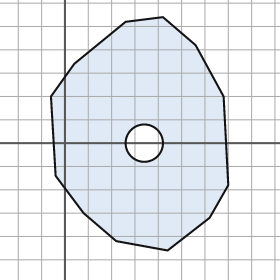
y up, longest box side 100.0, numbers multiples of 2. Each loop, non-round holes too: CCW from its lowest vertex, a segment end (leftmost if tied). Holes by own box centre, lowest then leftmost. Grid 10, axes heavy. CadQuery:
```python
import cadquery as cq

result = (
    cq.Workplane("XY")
    .moveTo(44.0, -46.0)
    .lineTo(62.0, -32.0)
    .lineTo(70.0, -18.0)
    .lineTo(68.0, 20.0)
    .lineTo(56.0, 42.0)
    .lineTo(42.0, 54.0)
    .lineTo(26.0, 52.0)
    .lineTo(4.0, 34.0)
    .lineTo(-6.0, 20.0)
    .lineTo(-4.0, -14.0)
    .lineTo(8.0, -30.0)
    .lineTo(22.0, -42.0)
    .close()
    .moveTo(34.0, 0.0)
    .circle(8.0)
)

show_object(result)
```